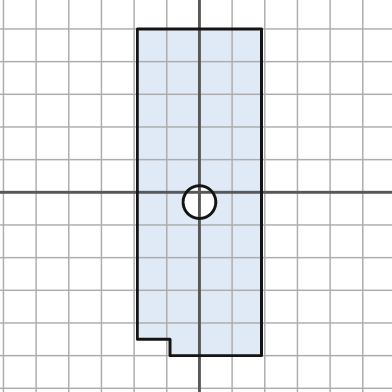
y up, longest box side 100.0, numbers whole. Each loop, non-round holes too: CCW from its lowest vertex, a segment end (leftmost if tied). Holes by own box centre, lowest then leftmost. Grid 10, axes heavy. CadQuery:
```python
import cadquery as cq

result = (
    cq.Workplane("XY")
    .moveTo(-9.0, -50.0)
    .lineTo(19.0, -50.0)
    .lineTo(19.0, 50.0)
    .lineTo(-19.0, 50.0)
    .lineTo(-19.0, -45.0)
    .lineTo(-9.0, -45.0)
    .close()
    .moveTo(0.0, -3.0)
    .circle(5.0)
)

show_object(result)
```